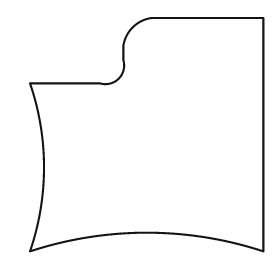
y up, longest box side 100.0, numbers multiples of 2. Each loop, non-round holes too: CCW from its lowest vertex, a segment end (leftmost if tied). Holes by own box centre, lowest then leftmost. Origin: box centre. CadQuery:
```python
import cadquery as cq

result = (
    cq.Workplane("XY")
    .moveTo(-50.0, -50.0)
    .threePointArc((0.0, -42.0), (50.0, -50.0))
    .lineTo(50.0, 50.0)
    .lineTo(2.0, 50.0)
    .threePointArc((-6.0, 46.0), (-10.0, 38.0))
    .lineTo(-10.0, 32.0)
    .threePointArc((-12.0, 24.0), (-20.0, 22.0))
    .lineTo(-50.0, 22.0)
    .threePointArc((-44.0, -14.0), (-50.0, -50.0))
    .close()
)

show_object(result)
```